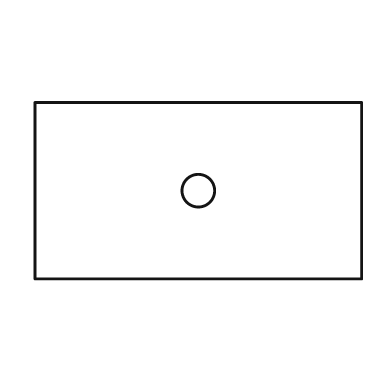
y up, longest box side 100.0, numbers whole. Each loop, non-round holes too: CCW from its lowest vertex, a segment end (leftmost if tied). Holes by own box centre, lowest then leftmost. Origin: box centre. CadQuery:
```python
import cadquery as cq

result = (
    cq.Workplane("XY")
    .moveTo(-50.0, -27.0)
    .lineTo(50.0, -27.0)
    .lineTo(50.0, 27.0)
    .lineTo(-50.0, 27.0)
    .close()
    .moveTo(0.0, 0.0)
    .circle(5.0)
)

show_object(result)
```